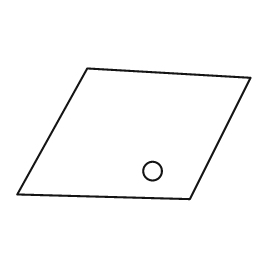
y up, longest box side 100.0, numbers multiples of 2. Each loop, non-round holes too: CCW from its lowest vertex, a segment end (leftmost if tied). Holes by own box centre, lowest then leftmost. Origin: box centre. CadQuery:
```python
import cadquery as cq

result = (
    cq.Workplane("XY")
    .moveTo(24.0, -28.0)
    .lineTo(50.0, 24.0)
    .lineTo(-20.0, 28.0)
    .lineTo(-50.0, -26.0)
    .close()
    .moveTo(8.0, -16.0)
    .circle(4.0)
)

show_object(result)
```